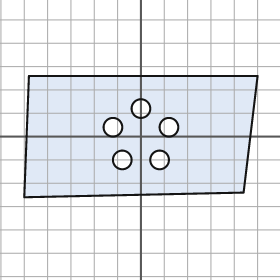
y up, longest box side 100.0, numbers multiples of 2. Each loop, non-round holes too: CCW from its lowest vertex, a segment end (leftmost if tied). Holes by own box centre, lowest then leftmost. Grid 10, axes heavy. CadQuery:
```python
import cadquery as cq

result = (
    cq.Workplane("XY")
    .moveTo(-50.0, -26.0)
    .lineTo(44.0, -24.0)
    .lineTo(50.0, 26.0)
    .lineTo(-48.0, 26.0)
    .close()
    .moveTo(-8.0, -10.0)
    .circle(4.0)
    .moveTo(8.0, -10.0)
    .circle(4.0)
    .moveTo(-12.0, 4.0)
    .circle(4.0)
    .moveTo(12.0, 4.0)
    .circle(4.0)
    .moveTo(0.0, 12.0)
    .circle(4.0)
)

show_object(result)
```